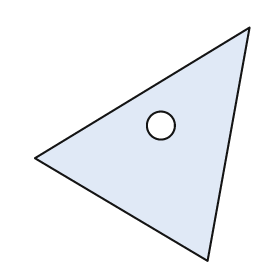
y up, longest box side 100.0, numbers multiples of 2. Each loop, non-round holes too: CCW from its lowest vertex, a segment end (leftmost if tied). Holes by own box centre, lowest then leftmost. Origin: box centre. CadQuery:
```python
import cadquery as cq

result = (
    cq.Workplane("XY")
    .moveTo(28.0, -50.0)
    .lineTo(46.0, 50.0)
    .lineTo(-46.0, -6.0)
    .close()
    .moveTo(8.0, 8.0)
    .circle(6.0)
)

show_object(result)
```